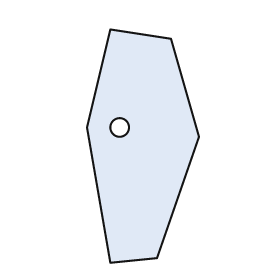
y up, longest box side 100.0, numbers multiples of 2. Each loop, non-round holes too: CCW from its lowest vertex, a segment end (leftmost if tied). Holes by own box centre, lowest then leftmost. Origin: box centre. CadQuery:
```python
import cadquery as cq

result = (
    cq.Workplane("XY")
    .moveTo(-14.0, -50.0)
    .lineTo(6.0, -48.0)
    .lineTo(24.0, 4.0)
    .lineTo(12.0, 46.0)
    .lineTo(-14.0, 50.0)
    .lineTo(-24.0, 8.0)
    .close()
    .moveTo(-10.0, 8.0)
    .circle(4.0)
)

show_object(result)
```